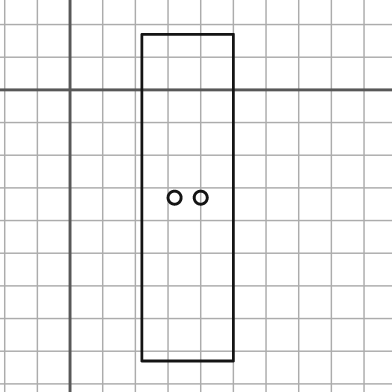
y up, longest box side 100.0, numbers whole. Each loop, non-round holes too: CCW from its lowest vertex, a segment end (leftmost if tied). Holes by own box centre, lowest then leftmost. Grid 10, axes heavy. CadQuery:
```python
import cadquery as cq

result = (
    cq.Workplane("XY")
    .moveTo(22.0, -83.0)
    .lineTo(50.0, -83.0)
    .lineTo(50.0, 17.0)
    .lineTo(22.0, 17.0)
    .close()
    .moveTo(32.0, -33.0)
    .circle(2.0)
    .moveTo(40.0, -33.0)
    .circle(2.0)
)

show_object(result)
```